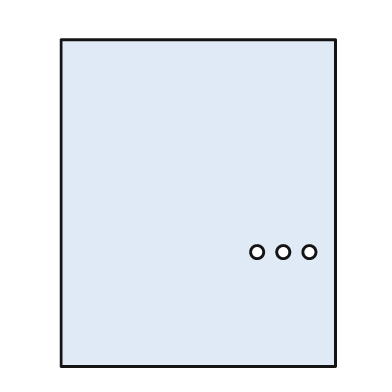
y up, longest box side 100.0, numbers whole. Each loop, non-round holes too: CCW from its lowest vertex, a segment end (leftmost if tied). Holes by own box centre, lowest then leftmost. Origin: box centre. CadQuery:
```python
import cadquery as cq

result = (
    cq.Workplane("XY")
    .moveTo(-42.0, -50.0)
    .lineTo(42.0, -50.0)
    .lineTo(42.0, 50.0)
    .lineTo(-42.0, 50.0)
    .close()
    .moveTo(18.0, -15.0)
    .circle(2.0)
    .moveTo(26.0, -15.0)
    .circle(2.0)
    .moveTo(34.0, -15.0)
    .circle(2.0)
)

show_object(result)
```